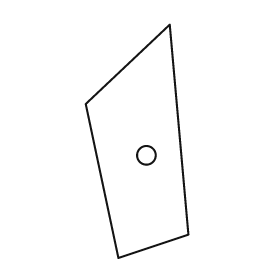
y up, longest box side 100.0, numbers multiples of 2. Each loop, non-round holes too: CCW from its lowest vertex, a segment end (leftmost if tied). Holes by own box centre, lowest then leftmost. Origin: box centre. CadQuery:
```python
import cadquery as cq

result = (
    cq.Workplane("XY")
    .moveTo(-8.0, -50.0)
    .lineTo(22.0, -40.0)
    .lineTo(14.0, 50.0)
    .lineTo(-22.0, 16.0)
    .close()
    .moveTo(4.0, -6.0)
    .circle(4.0)
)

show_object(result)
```